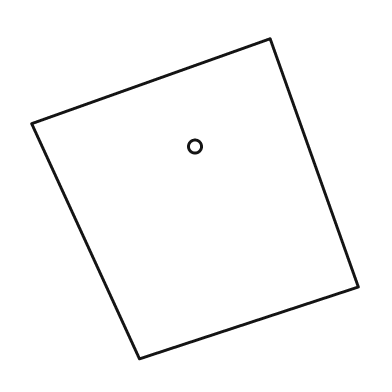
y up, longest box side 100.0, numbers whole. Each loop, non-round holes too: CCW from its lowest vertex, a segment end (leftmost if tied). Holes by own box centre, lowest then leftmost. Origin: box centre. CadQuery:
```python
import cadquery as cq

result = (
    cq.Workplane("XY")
    .moveTo(-17.0, -49.0)
    .lineTo(50.0, -27.0)
    .lineTo(23.0, 49.0)
    .lineTo(-50.0, 23.0)
    .close()
    .moveTo(0.0, 16.0)
    .circle(2.0)
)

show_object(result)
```